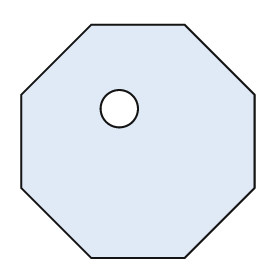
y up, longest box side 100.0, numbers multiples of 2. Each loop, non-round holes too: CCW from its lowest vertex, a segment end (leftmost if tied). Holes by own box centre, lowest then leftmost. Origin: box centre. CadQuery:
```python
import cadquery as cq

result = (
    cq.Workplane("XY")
    .moveTo(-20.0, -50.0)
    .lineTo(20.0, -50.0)
    .lineTo(50.0, -20.0)
    .lineTo(50.0, 20.0)
    .lineTo(20.0, 50.0)
    .lineTo(-20.0, 50.0)
    .lineTo(-50.0, 20.0)
    .lineTo(-50.0, -20.0)
    .close()
    .moveTo(-8.0, 14.0)
    .circle(8.0)
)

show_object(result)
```